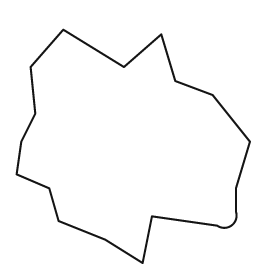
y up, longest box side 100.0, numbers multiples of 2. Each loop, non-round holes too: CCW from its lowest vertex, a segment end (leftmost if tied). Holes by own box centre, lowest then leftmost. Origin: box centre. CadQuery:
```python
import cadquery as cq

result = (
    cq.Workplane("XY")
    .moveTo(4.0, -50.0)
    .lineTo(8.0, -30.0)
    .lineTo(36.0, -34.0)
    .threePointArc((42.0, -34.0), (44.0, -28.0))
    .lineTo(44.0, -18.0)
    .lineTo(50.0, 2.0)
    .lineTo(34.0, 22.0)
    .lineTo(18.0, 28.0)
    .lineTo(12.0, 48.0)
    .lineTo(-4.0, 34.0)
    .lineTo(-30.0, 50.0)
    .lineTo(-44.0, 34.0)
    .lineTo(-42.0, 14.0)
    .lineTo(-48.0, 2.0)
    .lineTo(-50.0, -12.0)
    .lineTo(-36.0, -18.0)
    .lineTo(-32.0, -32.0)
    .lineTo(-12.0, -40.0)
    .close()
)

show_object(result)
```